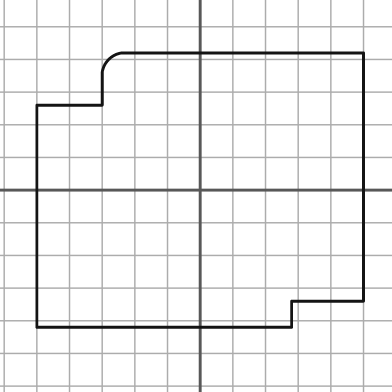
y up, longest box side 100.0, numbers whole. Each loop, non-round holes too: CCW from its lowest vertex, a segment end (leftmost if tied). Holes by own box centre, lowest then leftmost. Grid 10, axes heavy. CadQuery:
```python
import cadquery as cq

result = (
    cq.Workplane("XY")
    .moveTo(-50.0, -42.0)
    .lineTo(28.0, -42.0)
    .lineTo(28.0, -34.0)
    .lineTo(50.0, -34.0)
    .lineTo(50.0, 42.0)
    .lineTo(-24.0, 42.0)
    .threePointArc((-28.0, 40.0), (-30.0, 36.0))
    .lineTo(-30.0, 26.0)
    .lineTo(-50.0, 26.0)
    .close()
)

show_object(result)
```